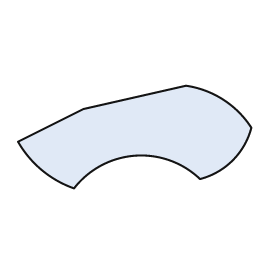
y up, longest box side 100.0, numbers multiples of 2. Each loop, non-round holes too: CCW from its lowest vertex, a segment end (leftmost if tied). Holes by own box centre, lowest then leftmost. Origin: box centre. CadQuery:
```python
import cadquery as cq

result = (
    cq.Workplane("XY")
    .moveTo(-26.0, -22.0)
    .threePointArc((0.0, -8.0), (28.0, -18.0))
    .threePointArc((42.0, -10.0), (50.0, 4.0))
    .threePointArc((38.0, 16.0), (22.0, 22.0))
    .lineTo(-22.0, 12.0)
    .lineTo(-50.0, -2.0)
    .threePointArc((-40.0, -14.0), (-26.0, -22.0))
    .close()
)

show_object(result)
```